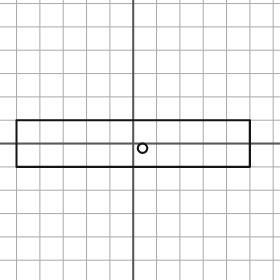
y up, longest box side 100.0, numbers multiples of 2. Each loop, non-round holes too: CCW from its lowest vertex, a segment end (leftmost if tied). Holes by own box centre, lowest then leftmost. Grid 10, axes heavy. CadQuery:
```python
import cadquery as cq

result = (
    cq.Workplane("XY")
    .moveTo(-50.0, -10.0)
    .lineTo(50.0, -10.0)
    .lineTo(50.0, 10.0)
    .lineTo(-50.0, 10.0)
    .close()
    .moveTo(4.0, -2.0)
    .circle(2.0)
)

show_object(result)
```